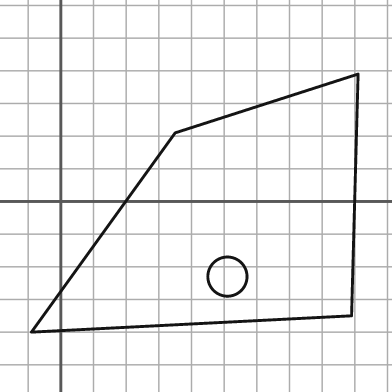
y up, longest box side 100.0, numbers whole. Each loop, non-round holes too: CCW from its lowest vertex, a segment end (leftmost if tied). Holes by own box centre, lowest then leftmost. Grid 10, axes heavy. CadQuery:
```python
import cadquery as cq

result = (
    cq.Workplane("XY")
    .moveTo(-9.0, -40.0)
    .lineTo(89.0, -35.0)
    .lineTo(91.0, 39.0)
    .lineTo(35.0, 21.0)
    .close()
    .moveTo(51.0, -23.0)
    .circle(6.0)
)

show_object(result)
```